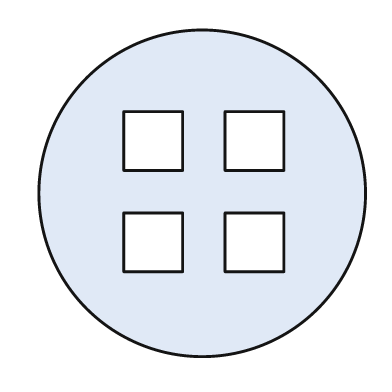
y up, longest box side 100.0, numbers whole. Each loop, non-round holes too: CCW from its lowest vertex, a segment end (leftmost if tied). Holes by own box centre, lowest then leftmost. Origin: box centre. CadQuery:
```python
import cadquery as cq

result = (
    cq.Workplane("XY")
    .moveTo(0.0, 0.0)
    .circle(50.0)
    .moveTo(-24.0, -24.0)
    .lineTo(-6.0, -24.0)
    .lineTo(-6.0, -6.0)
    .lineTo(-24.0, -6.0)
    .close()
    .moveTo(7.0, -24.0)
    .lineTo(25.0, -24.0)
    .lineTo(25.0, -6.0)
    .lineTo(7.0, -6.0)
    .close()
    .moveTo(-24.0, 7.0)
    .lineTo(-6.0, 7.0)
    .lineTo(-6.0, 25.0)
    .lineTo(-24.0, 25.0)
    .close()
    .moveTo(7.0, 7.0)
    .lineTo(25.0, 7.0)
    .lineTo(25.0, 25.0)
    .lineTo(7.0, 25.0)
    .close()
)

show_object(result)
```